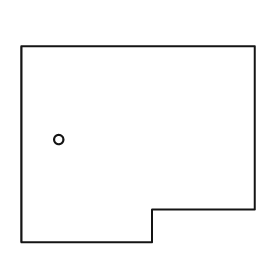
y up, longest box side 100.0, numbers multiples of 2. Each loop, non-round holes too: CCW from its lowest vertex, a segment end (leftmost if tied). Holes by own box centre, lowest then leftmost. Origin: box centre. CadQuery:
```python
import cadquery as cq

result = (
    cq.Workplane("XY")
    .moveTo(-50.0, -42.0)
    .lineTo(6.0, -42.0)
    .lineTo(6.0, -28.0)
    .lineTo(50.0, -28.0)
    .lineTo(50.0, 42.0)
    .lineTo(-50.0, 42.0)
    .close()
    .moveTo(-34.0, 2.0)
    .circle(2.0)
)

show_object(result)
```